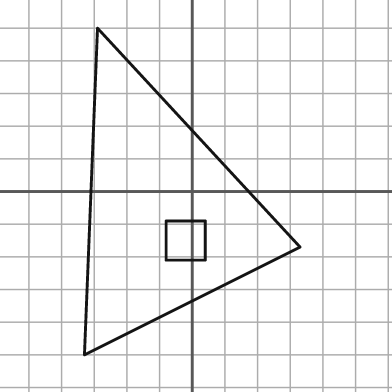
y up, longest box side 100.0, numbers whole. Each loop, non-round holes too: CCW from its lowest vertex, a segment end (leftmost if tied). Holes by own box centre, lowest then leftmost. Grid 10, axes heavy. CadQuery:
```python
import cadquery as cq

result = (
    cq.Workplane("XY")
    .moveTo(-33.0, -50.0)
    .lineTo(33.0, -17.0)
    .lineTo(-29.0, 50.0)
    .close()
    .moveTo(-8.0, -21.0)
    .lineTo(4.0, -21.0)
    .lineTo(4.0, -9.0)
    .lineTo(-8.0, -9.0)
    .close()
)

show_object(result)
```